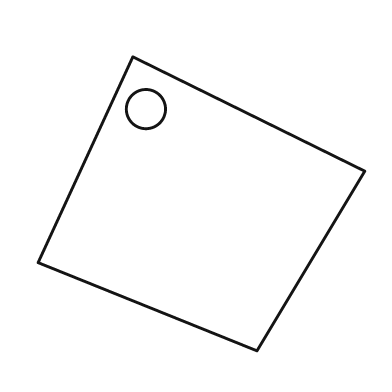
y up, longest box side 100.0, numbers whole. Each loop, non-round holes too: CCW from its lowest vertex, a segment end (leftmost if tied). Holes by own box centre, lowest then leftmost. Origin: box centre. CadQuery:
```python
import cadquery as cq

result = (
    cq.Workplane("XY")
    .moveTo(17.0, -45.0)
    .lineTo(50.0, 10.0)
    .lineTo(-21.0, 45.0)
    .lineTo(-50.0, -18.0)
    .close()
    .moveTo(-17.0, 29.0)
    .circle(6.0)
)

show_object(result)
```